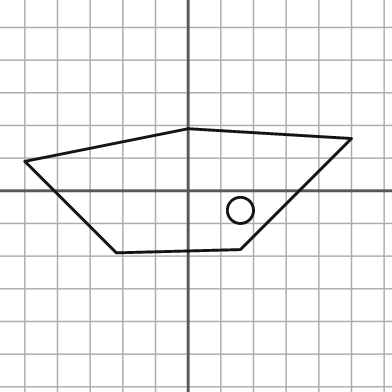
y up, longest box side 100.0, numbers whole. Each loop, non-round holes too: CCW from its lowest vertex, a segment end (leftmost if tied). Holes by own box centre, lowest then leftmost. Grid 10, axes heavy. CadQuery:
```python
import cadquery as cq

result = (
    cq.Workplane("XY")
    .moveTo(-22.0, -19.0)
    .lineTo(16.0, -18.0)
    .lineTo(50.0, 16.0)
    .lineTo(0.0, 19.0)
    .lineTo(-50.0, 9.0)
    .close()
    .moveTo(16.0, -6.0)
    .circle(4.0)
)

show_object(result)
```